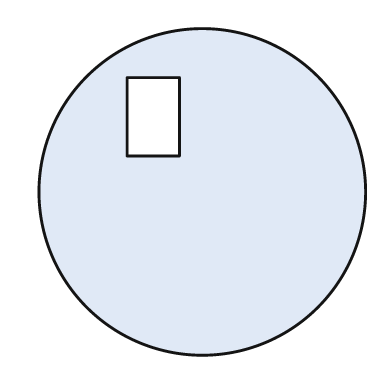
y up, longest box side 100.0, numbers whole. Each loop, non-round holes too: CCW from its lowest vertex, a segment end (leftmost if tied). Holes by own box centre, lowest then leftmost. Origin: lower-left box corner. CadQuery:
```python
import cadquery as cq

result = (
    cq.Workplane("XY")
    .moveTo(50.0, 50.0)
    .circle(50.0)
    .moveTo(27.0, 61.0)
    .lineTo(43.0, 61.0)
    .lineTo(43.0, 85.0)
    .lineTo(27.0, 85.0)
    .close()
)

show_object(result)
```